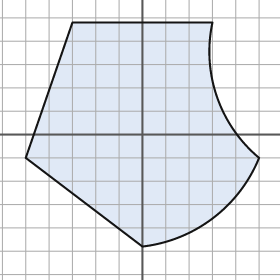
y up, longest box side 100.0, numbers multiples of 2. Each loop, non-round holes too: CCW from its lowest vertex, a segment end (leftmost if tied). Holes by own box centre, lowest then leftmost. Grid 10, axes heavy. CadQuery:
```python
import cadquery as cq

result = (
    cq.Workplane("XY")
    .moveTo(0.0, -48.0)
    .threePointArc((30.0, -36.0), (50.0, -10.0))
    .threePointArc((32.0, 16.0), (30.0, 48.0))
    .lineTo(-30.0, 48.0)
    .lineTo(-50.0, -10.0)
    .close()
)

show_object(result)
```